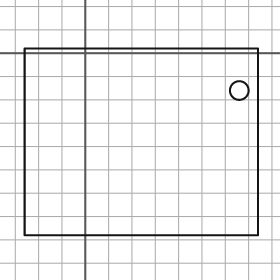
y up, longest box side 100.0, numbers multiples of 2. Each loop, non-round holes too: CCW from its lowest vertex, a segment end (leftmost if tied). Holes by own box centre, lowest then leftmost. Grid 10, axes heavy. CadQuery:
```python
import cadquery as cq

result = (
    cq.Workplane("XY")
    .moveTo(-26.0, -78.0)
    .lineTo(74.0, -78.0)
    .lineTo(74.0, 2.0)
    .lineTo(-26.0, 2.0)
    .close()
    .moveTo(66.0, -16.0)
    .circle(4.0)
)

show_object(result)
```